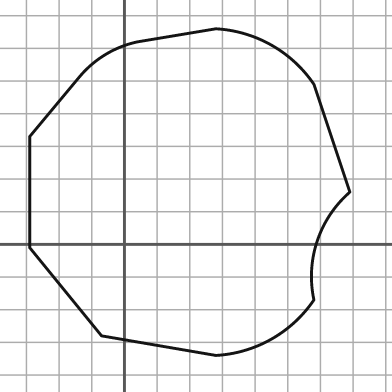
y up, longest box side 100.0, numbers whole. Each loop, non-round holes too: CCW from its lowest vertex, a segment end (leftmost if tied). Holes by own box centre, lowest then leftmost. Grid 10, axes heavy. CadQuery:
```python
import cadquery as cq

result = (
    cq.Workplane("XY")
    .moveTo(28.0, -34.0)
    .threePointArc((45.0, -29.0), (58.0, -17.0))
    .threePointArc((59.0, 1.0), (69.0, 16.0))
    .lineTo(58.0, 49.0)
    .threePointArc((45.0, 61.0), (28.0, 66.0))
    .lineTo(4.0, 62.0)
    .threePointArc((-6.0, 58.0), (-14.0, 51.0))
    .lineTo(-29.0, 33.0)
    .lineTo(-29.0, -1.0)
    .lineTo(-7.0, -28.0)
    .close()
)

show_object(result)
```